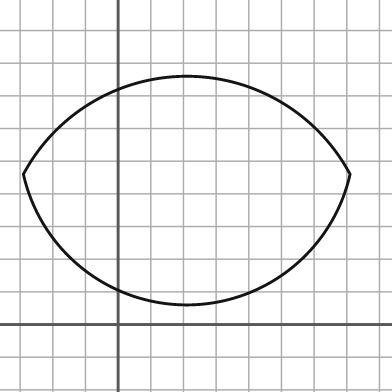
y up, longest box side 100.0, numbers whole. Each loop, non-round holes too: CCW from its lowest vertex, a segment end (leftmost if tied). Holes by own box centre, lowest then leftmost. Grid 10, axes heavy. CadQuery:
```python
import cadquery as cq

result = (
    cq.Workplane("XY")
    .moveTo(-29.0, 46.0)
    .threePointArc((21.0, 6.0), (71.0, 46.0))
    .threePointArc((21.0, 76.0), (-29.0, 46.0))
    .close()
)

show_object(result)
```